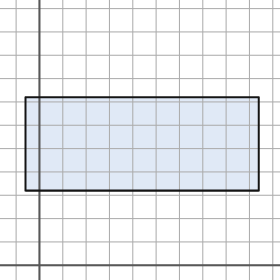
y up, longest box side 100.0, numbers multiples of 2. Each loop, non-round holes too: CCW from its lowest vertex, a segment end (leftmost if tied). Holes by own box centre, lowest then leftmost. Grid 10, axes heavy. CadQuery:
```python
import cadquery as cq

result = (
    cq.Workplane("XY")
    .moveTo(-6.0, 32.0)
    .lineTo(94.0, 32.0)
    .lineTo(94.0, 72.0)
    .lineTo(-6.0, 72.0)
    .close()
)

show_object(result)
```